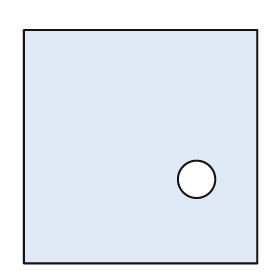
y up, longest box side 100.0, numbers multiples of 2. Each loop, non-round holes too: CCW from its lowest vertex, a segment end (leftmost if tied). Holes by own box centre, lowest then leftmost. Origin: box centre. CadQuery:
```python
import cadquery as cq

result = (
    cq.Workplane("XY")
    .moveTo(-50.0, -50.0)
    .lineTo(50.0, -50.0)
    .lineTo(50.0, 50.0)
    .lineTo(-50.0, 50.0)
    .close()
    .moveTo(24.0, -14.0)
    .circle(8.0)
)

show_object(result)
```